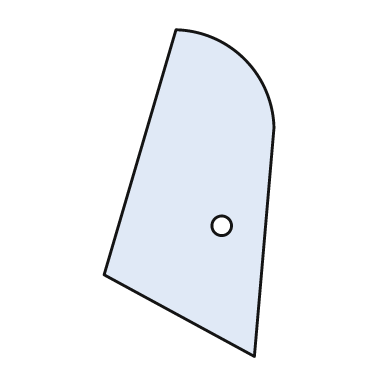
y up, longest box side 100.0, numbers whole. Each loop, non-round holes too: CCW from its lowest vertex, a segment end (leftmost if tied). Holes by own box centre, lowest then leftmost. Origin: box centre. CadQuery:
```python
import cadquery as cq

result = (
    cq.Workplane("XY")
    .moveTo(20.0, -50.0)
    .lineTo(26.0, 20.0)
    .threePointArc((17.0, 41.0), (-4.0, 50.0))
    .lineTo(-26.0, -25.0)
    .close()
    .moveTo(10.0, -10.0)
    .circle(3.0)
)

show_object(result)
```